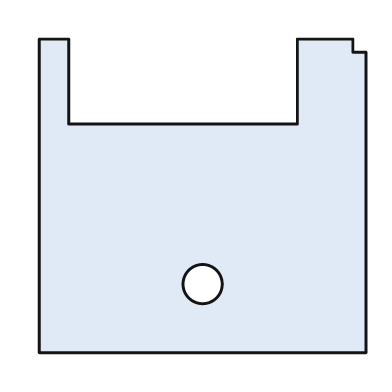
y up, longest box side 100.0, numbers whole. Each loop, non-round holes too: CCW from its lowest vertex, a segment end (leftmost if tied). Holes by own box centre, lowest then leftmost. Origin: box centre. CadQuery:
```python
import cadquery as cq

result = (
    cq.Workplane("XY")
    .moveTo(-50.0, -48.0)
    .lineTo(50.0, -48.0)
    .lineTo(50.0, 44.0)
    .lineTo(46.0, 44.0)
    .lineTo(46.0, 48.0)
    .lineTo(29.0, 48.0)
    .lineTo(29.0, 22.0)
    .lineTo(-41.0, 22.0)
    .lineTo(-41.0, 48.0)
    .lineTo(-50.0, 48.0)
    .close()
    .moveTo(0.0, -27.0)
    .circle(6.0)
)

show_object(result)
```